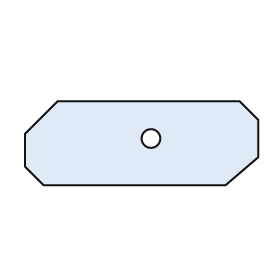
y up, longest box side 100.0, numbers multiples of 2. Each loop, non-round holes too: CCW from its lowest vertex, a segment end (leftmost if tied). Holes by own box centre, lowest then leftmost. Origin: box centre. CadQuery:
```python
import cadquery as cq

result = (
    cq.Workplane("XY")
    .moveTo(-42.0, -18.0)
    .lineTo(36.0, -18.0)
    .lineTo(50.0, -6.0)
    .lineTo(50.0, 10.0)
    .lineTo(42.0, 18.0)
    .lineTo(-36.0, 18.0)
    .lineTo(-50.0, 4.0)
    .lineTo(-50.0, -10.0)
    .close()
    .moveTo(4.0, 2.0)
    .circle(4.0)
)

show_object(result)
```